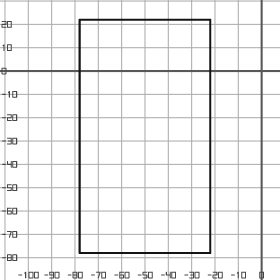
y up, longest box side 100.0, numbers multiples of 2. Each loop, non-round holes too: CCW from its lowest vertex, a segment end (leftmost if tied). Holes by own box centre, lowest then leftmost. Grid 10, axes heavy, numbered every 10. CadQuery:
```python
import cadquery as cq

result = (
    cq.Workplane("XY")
    .moveTo(-78.0, -78.0)
    .lineTo(-22.0, -78.0)
    .lineTo(-22.0, 22.0)
    .lineTo(-78.0, 22.0)
    .close()
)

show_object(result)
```